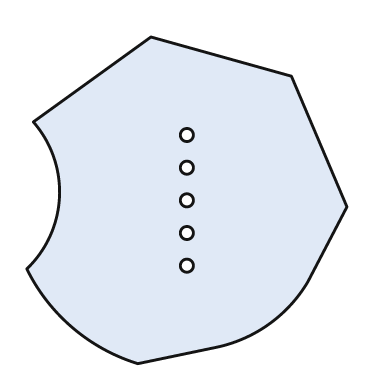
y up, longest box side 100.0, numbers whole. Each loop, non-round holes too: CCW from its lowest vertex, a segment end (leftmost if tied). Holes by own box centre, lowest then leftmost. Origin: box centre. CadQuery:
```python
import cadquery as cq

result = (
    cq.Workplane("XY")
    .moveTo(-15.0, -50.0)
    .lineTo(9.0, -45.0)
    .threePointArc((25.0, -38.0), (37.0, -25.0))
    .lineTo(49.0, -2.0)
    .lineTo(32.0, 38.0)
    .lineTo(-11.0, 50.0)
    .lineTo(-47.0, 24.0)
    .threePointArc((-39.0, 1.0), (-49.0, -21.0))
    .threePointArc((-35.0, -39.0), (-15.0, -50.0))
    .close()
    .moveTo(0.0, -20.0)
    .circle(2.0)
    .moveTo(0.0, -10.0)
    .circle(2.0)
    .moveTo(0.0, 0.0)
    .circle(2.0)
    .moveTo(0.0, 10.0)
    .circle(2.0)
    .moveTo(0.0, 20.0)
    .circle(2.0)
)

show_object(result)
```